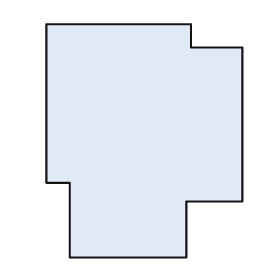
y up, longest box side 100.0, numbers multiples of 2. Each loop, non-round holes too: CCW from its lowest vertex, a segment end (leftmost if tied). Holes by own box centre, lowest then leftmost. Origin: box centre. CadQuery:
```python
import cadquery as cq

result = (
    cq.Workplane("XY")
    .moveTo(-32.0, -50.0)
    .lineTo(18.0, -50.0)
    .lineTo(18.0, -26.0)
    .lineTo(42.0, -26.0)
    .lineTo(42.0, 40.0)
    .lineTo(20.0, 40.0)
    .lineTo(20.0, 50.0)
    .lineTo(-42.0, 50.0)
    .lineTo(-42.0, -18.0)
    .lineTo(-32.0, -18.0)
    .close()
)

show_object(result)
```